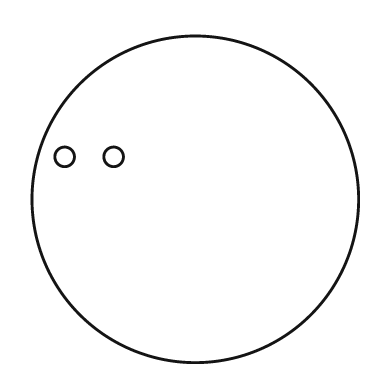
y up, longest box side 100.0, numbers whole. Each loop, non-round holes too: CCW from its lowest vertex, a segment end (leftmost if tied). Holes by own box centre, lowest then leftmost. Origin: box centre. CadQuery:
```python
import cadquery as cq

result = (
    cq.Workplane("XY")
    .moveTo(0.0, 0.0)
    .circle(50.0)
    .moveTo(-40.0, 13.0)
    .circle(3.0)
    .moveTo(-25.0, 13.0)
    .circle(3.0)
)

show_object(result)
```